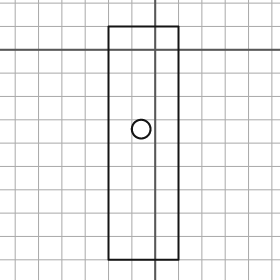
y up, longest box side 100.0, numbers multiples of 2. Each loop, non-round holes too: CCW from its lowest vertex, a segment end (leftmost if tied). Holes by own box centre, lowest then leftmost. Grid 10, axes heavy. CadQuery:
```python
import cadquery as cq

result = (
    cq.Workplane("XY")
    .moveTo(-20.0, -90.0)
    .lineTo(10.0, -90.0)
    .lineTo(10.0, 10.0)
    .lineTo(-20.0, 10.0)
    .close()
    .moveTo(-6.0, -34.0)
    .circle(4.0)
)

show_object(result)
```